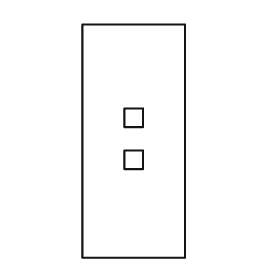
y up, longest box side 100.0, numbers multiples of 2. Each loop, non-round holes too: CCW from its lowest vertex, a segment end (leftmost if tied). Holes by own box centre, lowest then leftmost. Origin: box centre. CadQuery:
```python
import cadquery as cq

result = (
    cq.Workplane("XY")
    .moveTo(-22.0, -50.0)
    .lineTo(22.0, -50.0)
    .lineTo(22.0, 50.0)
    .lineTo(-22.0, 50.0)
    .close()
    .moveTo(-4.0, -12.0)
    .lineTo(4.0, -12.0)
    .lineTo(4.0, -4.0)
    .lineTo(-4.0, -4.0)
    .close()
    .moveTo(-4.0, 6.0)
    .lineTo(4.0, 6.0)
    .lineTo(4.0, 14.0)
    .lineTo(-4.0, 14.0)
    .close()
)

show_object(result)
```